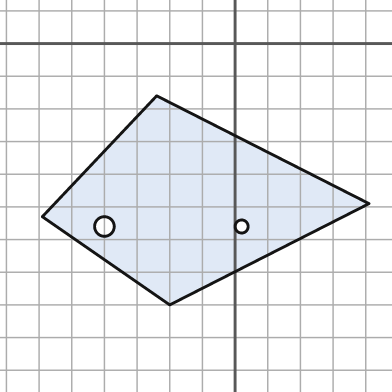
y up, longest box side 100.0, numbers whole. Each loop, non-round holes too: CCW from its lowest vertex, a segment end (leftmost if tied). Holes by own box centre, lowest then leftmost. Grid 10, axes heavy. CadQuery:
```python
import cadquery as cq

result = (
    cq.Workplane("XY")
    .moveTo(-20.0, -80.0)
    .lineTo(41.0, -49.0)
    .lineTo(-24.0, -16.0)
    .lineTo(-59.0, -53.0)
    .close()
    .moveTo(-40.0, -56.0)
    .circle(3.0)
    .moveTo(2.0, -56.0)
    .circle(2.0)
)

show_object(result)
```